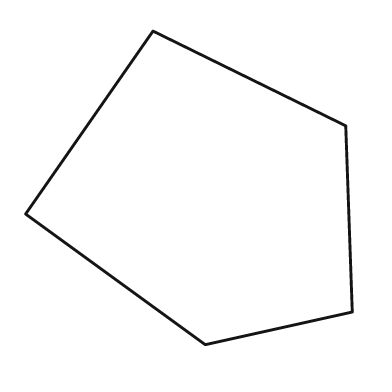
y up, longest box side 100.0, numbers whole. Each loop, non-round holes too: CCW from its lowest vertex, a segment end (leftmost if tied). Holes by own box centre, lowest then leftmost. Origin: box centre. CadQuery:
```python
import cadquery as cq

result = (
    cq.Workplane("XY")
    .moveTo(5.0, -48.0)
    .lineTo(50.0, -38.0)
    .lineTo(48.0, 19.0)
    .lineTo(-11.0, 48.0)
    .lineTo(-50.0, -8.0)
    .close()
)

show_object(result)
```